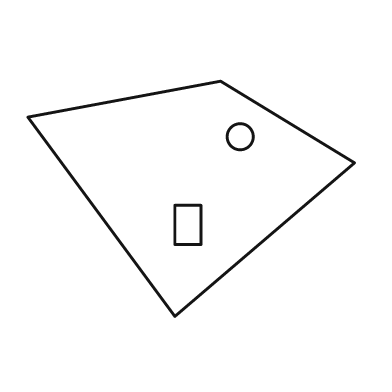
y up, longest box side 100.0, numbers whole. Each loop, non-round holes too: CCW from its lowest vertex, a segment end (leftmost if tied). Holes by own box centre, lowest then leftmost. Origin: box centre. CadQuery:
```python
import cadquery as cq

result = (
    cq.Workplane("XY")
    .moveTo(-5.0, -36.0)
    .lineTo(50.0, 11.0)
    .lineTo(9.0, 36.0)
    .lineTo(-50.0, 25.0)
    .close()
    .moveTo(-5.0, -14.0)
    .lineTo(3.0, -14.0)
    .lineTo(3.0, -2.0)
    .lineTo(-5.0, -2.0)
    .close()
    .moveTo(15.0, 19.0)
    .circle(4.0)
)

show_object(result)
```